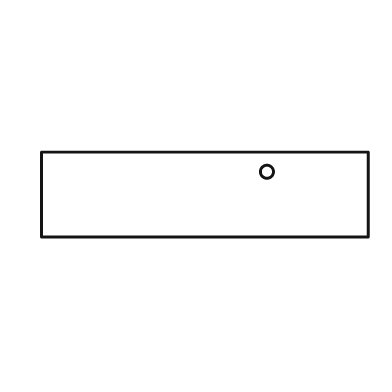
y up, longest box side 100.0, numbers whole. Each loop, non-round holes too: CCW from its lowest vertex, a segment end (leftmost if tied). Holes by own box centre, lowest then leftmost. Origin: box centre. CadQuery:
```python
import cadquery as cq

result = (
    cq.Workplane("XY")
    .moveTo(-50.0, -13.0)
    .lineTo(50.0, -13.0)
    .lineTo(50.0, 13.0)
    .lineTo(-50.0, 13.0)
    .close()
    .moveTo(19.0, 7.0)
    .circle(2.0)
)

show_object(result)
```